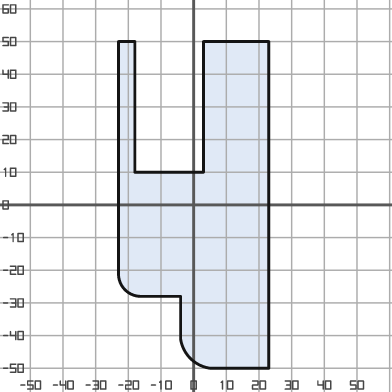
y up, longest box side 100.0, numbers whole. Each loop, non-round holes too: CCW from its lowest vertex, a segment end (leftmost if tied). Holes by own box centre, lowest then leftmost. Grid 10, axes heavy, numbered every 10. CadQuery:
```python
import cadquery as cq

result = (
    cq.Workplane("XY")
    .moveTo(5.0, -50.0)
    .lineTo(23.0, -50.0)
    .lineTo(23.0, 50.0)
    .lineTo(3.0, 50.0)
    .lineTo(3.0, 10.0)
    .lineTo(-18.0, 10.0)
    .lineTo(-18.0, 50.0)
    .lineTo(-23.0, 50.0)
    .lineTo(-23.0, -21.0)
    .threePointArc((-21.0, -26.0), (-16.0, -28.0))
    .lineTo(-4.0, -28.0)
    .lineTo(-4.0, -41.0)
    .threePointArc((-1.0, -47.0), (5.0, -50.0))
    .close()
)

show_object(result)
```